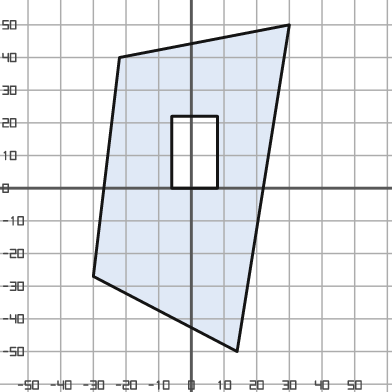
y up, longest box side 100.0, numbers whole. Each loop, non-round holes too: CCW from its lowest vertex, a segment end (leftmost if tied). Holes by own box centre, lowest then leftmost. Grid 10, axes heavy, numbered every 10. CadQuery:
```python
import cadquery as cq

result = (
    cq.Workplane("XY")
    .moveTo(14.0, -50.0)
    .lineTo(30.0, 50.0)
    .lineTo(-22.0, 40.0)
    .lineTo(-30.0, -27.0)
    .close()
    .moveTo(-6.0, 0.0)
    .lineTo(8.0, 0.0)
    .lineTo(8.0, 22.0)
    .lineTo(-6.0, 22.0)
    .close()
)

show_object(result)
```